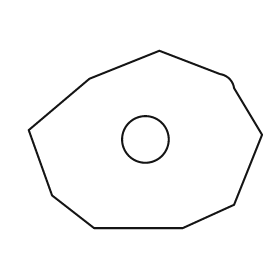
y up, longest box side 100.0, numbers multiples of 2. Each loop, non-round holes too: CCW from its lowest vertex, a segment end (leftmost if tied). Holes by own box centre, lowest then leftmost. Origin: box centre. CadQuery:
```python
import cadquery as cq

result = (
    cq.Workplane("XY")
    .moveTo(-22.0, -38.0)
    .lineTo(16.0, -38.0)
    .lineTo(38.0, -28.0)
    .lineTo(50.0, 2.0)
    .lineTo(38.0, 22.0)
    .threePointArc((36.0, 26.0), (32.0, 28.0))
    .lineTo(6.0, 38.0)
    .lineTo(-24.0, 26.0)
    .lineTo(-50.0, 4.0)
    .lineTo(-40.0, -24.0)
    .close()
    .moveTo(0.0, 0.0)
    .circle(10.0)
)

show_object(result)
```